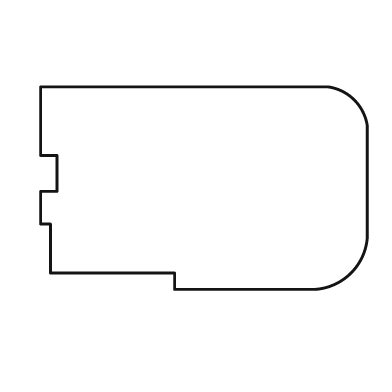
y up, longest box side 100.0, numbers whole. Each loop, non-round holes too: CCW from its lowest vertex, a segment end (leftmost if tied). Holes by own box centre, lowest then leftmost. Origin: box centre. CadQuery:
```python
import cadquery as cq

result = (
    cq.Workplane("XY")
    .moveTo(-9.0, -31.0)
    .lineTo(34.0, -31.0)
    .threePointArc((45.0, -26.0), (50.0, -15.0))
    .lineTo(50.0, 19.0)
    .threePointArc((46.0, 27.0), (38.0, 31.0))
    .lineTo(-50.0, 31.0)
    .lineTo(-50.0, 10.0)
    .lineTo(-45.0, 10.0)
    .lineTo(-45.0, -1.0)
    .lineTo(-50.0, -1.0)
    .lineTo(-50.0, -11.0)
    .lineTo(-47.0, -11.0)
    .lineTo(-47.0, -26.0)
    .lineTo(-9.0, -26.0)
    .close()
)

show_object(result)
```